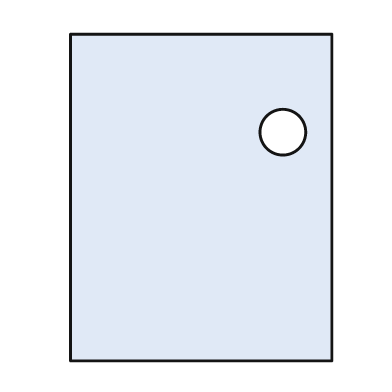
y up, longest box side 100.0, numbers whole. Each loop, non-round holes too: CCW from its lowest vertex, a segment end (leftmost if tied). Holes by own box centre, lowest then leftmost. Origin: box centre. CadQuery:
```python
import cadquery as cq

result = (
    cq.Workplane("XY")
    .moveTo(-40.0, -50.0)
    .lineTo(40.0, -50.0)
    .lineTo(40.0, 50.0)
    .lineTo(-40.0, 50.0)
    .close()
    .moveTo(25.0, 20.0)
    .circle(7.0)
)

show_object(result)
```